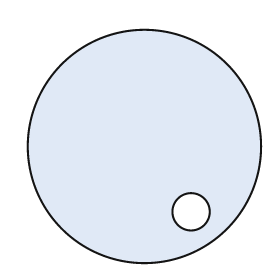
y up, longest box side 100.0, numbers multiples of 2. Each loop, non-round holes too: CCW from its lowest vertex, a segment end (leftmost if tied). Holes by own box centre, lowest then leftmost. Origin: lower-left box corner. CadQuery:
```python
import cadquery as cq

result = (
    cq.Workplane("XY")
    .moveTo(50.0, 50.0)
    .circle(50.0)
    .moveTo(70.0, 22.0)
    .circle(8.0)
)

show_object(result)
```